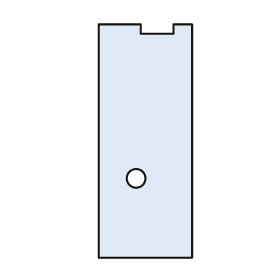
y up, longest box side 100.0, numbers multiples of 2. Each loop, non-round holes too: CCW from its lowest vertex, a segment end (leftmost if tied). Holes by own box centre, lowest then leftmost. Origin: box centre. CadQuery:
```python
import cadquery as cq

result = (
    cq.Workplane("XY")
    .moveTo(-20.0, -50.0)
    .lineTo(20.0, -50.0)
    .lineTo(20.0, 50.0)
    .lineTo(12.0, 50.0)
    .lineTo(12.0, 46.0)
    .lineTo(-2.0, 46.0)
    .lineTo(-2.0, 50.0)
    .lineTo(-20.0, 50.0)
    .close()
    .moveTo(-4.0, -16.0)
    .circle(4.0)
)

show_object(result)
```